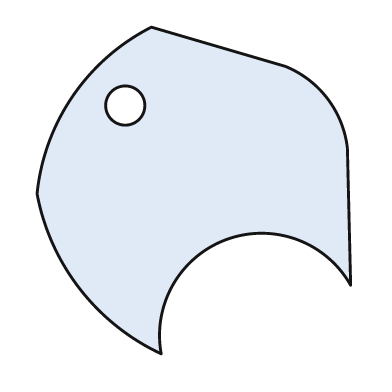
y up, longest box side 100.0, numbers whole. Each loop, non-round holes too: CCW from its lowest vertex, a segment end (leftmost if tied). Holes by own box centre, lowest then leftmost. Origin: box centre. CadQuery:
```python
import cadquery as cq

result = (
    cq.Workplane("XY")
    .moveTo(-10.0, -50.0)
    .threePointArc((10.0, -15.0), (48.0, -29.0))
    .lineTo(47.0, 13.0)
    .threePointArc((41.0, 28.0), (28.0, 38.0))
    .lineTo(-13.0, 50.0)
    .threePointArc((-37.0, 29.0), (-48.0, -1.0))
    .threePointArc((-35.0, -30.0), (-10.0, -50.0))
    .close()
    .moveTo(-21.0, 26.0)
    .circle(6.0)
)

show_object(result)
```